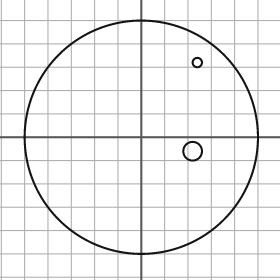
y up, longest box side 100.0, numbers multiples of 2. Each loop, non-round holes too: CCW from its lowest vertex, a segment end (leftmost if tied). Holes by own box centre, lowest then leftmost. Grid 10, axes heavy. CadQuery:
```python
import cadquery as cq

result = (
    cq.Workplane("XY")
    .moveTo(0.0, 0.0)
    .circle(50.0)
    .moveTo(22.0, -6.0)
    .circle(4.0)
    .moveTo(24.0, 32.0)
    .circle(2.0)
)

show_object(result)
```